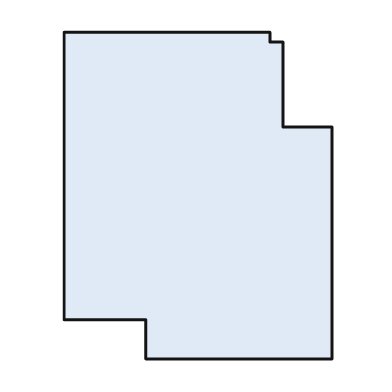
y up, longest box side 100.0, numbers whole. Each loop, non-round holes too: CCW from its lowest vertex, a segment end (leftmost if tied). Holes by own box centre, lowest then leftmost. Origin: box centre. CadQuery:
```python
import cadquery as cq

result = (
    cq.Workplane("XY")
    .moveTo(-16.0, -50.0)
    .lineTo(41.0, -50.0)
    .lineTo(41.0, 21.0)
    .lineTo(26.0, 21.0)
    .lineTo(26.0, 47.0)
    .lineTo(22.0, 47.0)
    .lineTo(22.0, 50.0)
    .lineTo(-41.0, 50.0)
    .lineTo(-41.0, -38.0)
    .lineTo(-16.0, -38.0)
    .close()
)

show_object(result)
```